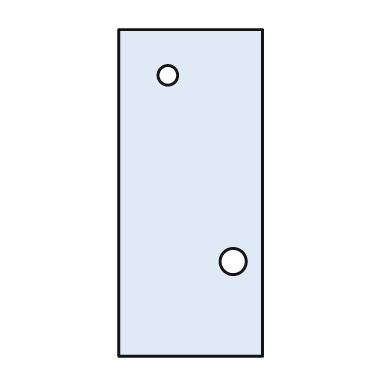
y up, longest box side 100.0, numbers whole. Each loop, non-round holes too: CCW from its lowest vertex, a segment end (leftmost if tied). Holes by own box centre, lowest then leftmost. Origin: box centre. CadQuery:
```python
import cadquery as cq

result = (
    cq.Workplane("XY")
    .moveTo(-22.0, -50.0)
    .lineTo(22.0, -50.0)
    .lineTo(22.0, 50.0)
    .lineTo(-22.0, 50.0)
    .close()
    .moveTo(13.0, -21.0)
    .circle(4.0)
    .moveTo(-7.0, 36.0)
    .circle(3.0)
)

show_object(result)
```